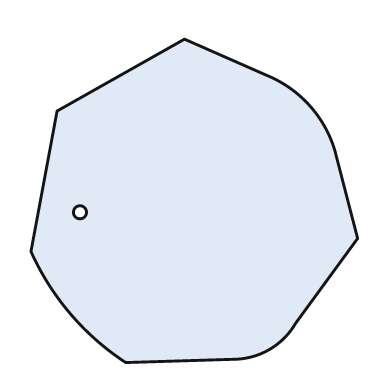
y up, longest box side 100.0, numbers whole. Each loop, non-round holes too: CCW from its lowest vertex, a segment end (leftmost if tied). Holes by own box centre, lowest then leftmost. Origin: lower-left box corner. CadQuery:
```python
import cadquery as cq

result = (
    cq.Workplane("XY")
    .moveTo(29.0, 0.0)
    .lineTo(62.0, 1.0)
    .threePointArc((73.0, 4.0), (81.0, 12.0))
    .lineTo(100.0, 38.0)
    .lineTo(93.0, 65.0)
    .threePointArc((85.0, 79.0), (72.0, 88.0))
    .lineTo(47.0, 99.0)
    .lineTo(8.0, 77.0)
    .lineTo(0.0, 34.0)
    .threePointArc((12.0, 15.0), (29.0, 0.0))
    .close()
    .moveTo(15.0, 46.0)
    .circle(2.0)
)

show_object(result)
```